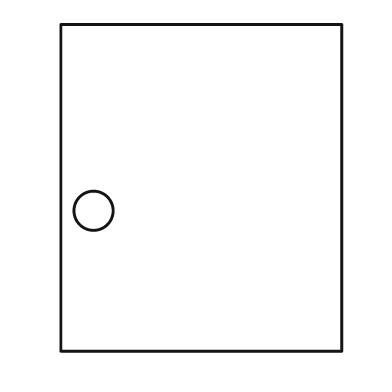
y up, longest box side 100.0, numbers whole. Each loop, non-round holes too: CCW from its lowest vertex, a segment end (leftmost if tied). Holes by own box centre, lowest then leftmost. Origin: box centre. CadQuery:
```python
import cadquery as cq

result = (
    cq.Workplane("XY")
    .moveTo(-43.0, -50.0)
    .lineTo(43.0, -50.0)
    .lineTo(43.0, 50.0)
    .lineTo(-43.0, 50.0)
    .close()
    .moveTo(-33.0, -7.0)
    .circle(6.0)
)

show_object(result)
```